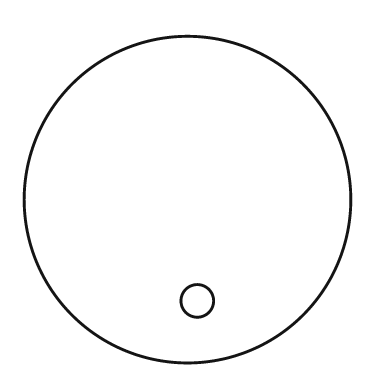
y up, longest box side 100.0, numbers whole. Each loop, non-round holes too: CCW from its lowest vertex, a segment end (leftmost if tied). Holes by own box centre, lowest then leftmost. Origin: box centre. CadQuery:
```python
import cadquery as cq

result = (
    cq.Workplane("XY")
    .moveTo(0.0, 0.0)
    .circle(50.0)
    .moveTo(3.0, -31.0)
    .circle(5.0)
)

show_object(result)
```